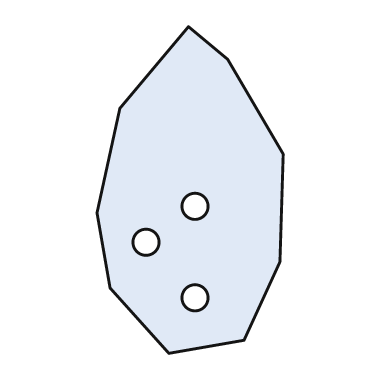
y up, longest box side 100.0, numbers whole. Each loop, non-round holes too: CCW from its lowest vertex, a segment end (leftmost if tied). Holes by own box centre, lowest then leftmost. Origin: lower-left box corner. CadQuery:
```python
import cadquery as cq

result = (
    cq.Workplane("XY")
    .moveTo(22.0, 0.0)
    .lineTo(45.0, 4.0)
    .lineTo(56.0, 28.0)
    .lineTo(57.0, 61.0)
    .lineTo(40.0, 90.0)
    .lineTo(28.0, 100.0)
    .lineTo(7.0, 75.0)
    .lineTo(0.0, 43.0)
    .lineTo(4.0, 20.0)
    .close()
    .moveTo(30.0, 17.0)
    .circle(4.0)
    .moveTo(15.0, 34.0)
    .circle(4.0)
    .moveTo(30.0, 45.0)
    .circle(4.0)
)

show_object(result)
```